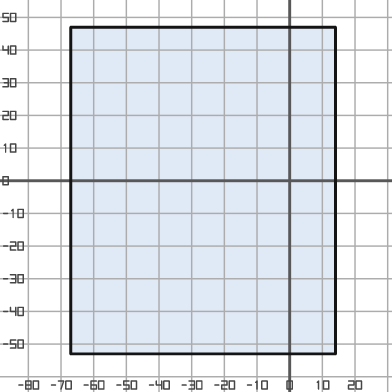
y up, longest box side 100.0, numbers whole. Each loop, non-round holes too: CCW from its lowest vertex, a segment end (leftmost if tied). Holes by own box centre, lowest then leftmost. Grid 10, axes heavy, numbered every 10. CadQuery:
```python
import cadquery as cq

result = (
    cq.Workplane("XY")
    .moveTo(-67.0, -53.0)
    .lineTo(14.0, -53.0)
    .lineTo(14.0, 47.0)
    .lineTo(-67.0, 47.0)
    .close()
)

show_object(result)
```